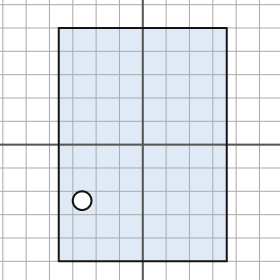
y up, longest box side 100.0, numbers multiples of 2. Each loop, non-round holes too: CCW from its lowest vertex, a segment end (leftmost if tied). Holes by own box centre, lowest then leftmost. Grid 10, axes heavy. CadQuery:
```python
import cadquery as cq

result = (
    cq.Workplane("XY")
    .moveTo(-36.0, -50.0)
    .lineTo(36.0, -50.0)
    .lineTo(36.0, 50.0)
    .lineTo(-36.0, 50.0)
    .close()
    .moveTo(-26.0, -24.0)
    .circle(4.0)
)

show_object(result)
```